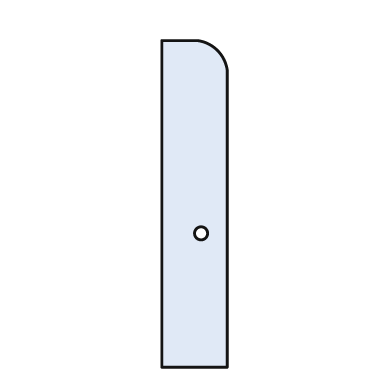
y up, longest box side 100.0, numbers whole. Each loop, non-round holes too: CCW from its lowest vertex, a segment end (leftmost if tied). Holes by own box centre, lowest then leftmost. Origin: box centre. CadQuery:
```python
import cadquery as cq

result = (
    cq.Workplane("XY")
    .moveTo(-10.0, -50.0)
    .lineTo(10.0, -50.0)
    .lineTo(10.0, 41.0)
    .threePointArc((7.0, 47.0), (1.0, 50.0))
    .lineTo(-10.0, 50.0)
    .close()
    .moveTo(2.0, -9.0)
    .circle(2.0)
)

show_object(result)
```